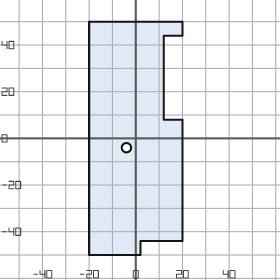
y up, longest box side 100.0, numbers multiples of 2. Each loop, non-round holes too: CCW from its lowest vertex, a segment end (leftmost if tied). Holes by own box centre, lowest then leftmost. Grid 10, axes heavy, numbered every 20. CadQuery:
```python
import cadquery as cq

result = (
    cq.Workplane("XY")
    .moveTo(-20.0, -50.0)
    .lineTo(2.0, -50.0)
    .lineTo(2.0, -44.0)
    .lineTo(20.0, -44.0)
    .lineTo(20.0, 8.0)
    .lineTo(12.0, 8.0)
    .lineTo(12.0, 44.0)
    .lineTo(20.0, 44.0)
    .lineTo(20.0, 50.0)
    .lineTo(-20.0, 50.0)
    .close()
    .moveTo(-4.0, -4.0)
    .circle(2.0)
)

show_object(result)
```